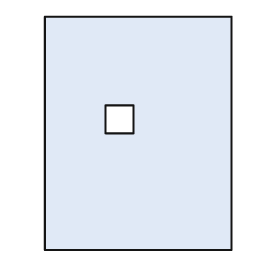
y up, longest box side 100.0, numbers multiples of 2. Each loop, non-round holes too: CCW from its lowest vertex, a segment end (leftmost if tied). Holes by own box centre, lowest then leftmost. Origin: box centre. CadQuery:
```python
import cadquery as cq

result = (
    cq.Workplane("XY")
    .moveTo(-40.0, -50.0)
    .lineTo(40.0, -50.0)
    .lineTo(40.0, 50.0)
    .lineTo(-40.0, 50.0)
    .close()
    .moveTo(-14.0, 0.0)
    .lineTo(-2.0, 0.0)
    .lineTo(-2.0, 12.0)
    .lineTo(-14.0, 12.0)
    .close()
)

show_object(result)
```